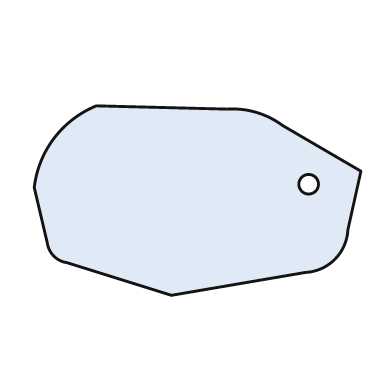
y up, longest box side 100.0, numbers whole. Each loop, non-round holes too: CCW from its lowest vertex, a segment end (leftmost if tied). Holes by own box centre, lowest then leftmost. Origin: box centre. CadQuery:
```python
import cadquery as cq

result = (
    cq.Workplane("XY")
    .moveTo(-8.0, -29.0)
    .lineTo(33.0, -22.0)
    .threePointArc((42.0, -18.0), (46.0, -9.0))
    .lineTo(50.0, 9.0)
    .lineTo(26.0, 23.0)
    .threePointArc((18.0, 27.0), (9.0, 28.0))
    .lineTo(-31.0, 29.0)
    .threePointArc((-44.0, 19.0), (-50.0, 4.0))
    .lineTo(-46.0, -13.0)
    .threePointArc((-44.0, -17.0), (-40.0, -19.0))
    .close()
    .moveTo(34.0, 5.0)
    .circle(3.0)
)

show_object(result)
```